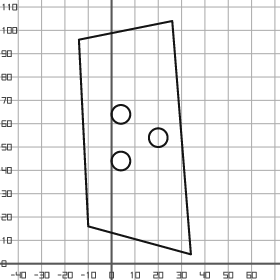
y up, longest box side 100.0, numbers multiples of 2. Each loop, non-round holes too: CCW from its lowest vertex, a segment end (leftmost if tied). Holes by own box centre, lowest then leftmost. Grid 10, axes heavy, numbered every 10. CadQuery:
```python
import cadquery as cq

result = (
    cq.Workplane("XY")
    .moveTo(34.0, 4.0)
    .lineTo(26.0, 104.0)
    .lineTo(-14.0, 96.0)
    .lineTo(-10.0, 16.0)
    .close()
    .moveTo(4.0, 44.0)
    .circle(4.0)
    .moveTo(20.0, 54.0)
    .circle(4.0)
    .moveTo(4.0, 64.0)
    .circle(4.0)
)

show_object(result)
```